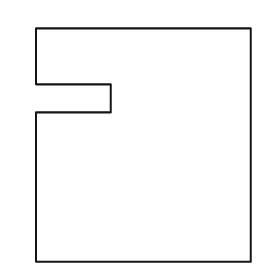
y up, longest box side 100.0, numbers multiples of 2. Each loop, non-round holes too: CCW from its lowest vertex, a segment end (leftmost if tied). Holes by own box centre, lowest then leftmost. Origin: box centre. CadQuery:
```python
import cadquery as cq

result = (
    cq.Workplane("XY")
    .moveTo(-46.0, -50.0)
    .lineTo(46.0, -50.0)
    .lineTo(46.0, 50.0)
    .lineTo(-46.0, 50.0)
    .lineTo(-46.0, 26.0)
    .lineTo(-14.0, 26.0)
    .lineTo(-14.0, 14.0)
    .lineTo(-46.0, 14.0)
    .close()
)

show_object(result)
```